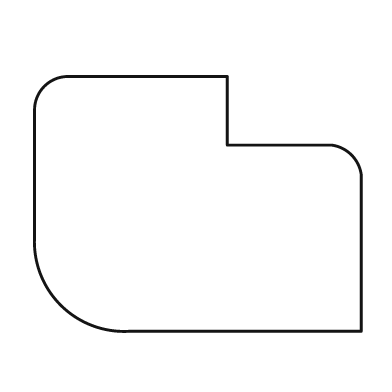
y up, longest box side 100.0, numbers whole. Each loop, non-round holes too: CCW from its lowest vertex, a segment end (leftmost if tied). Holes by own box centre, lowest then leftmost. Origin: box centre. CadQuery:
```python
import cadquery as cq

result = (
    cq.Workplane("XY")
    .moveTo(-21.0, -39.0)
    .lineTo(50.0, -39.0)
    .lineTo(50.0, 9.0)
    .threePointArc((47.0, 15.0), (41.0, 18.0))
    .lineTo(9.0, 18.0)
    .lineTo(9.0, 39.0)
    .lineTo(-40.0, 39.0)
    .threePointArc((-47.0, 36.0), (-50.0, 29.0))
    .lineTo(-50.0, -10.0)
    .threePointArc((-42.0, -31.0), (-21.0, -39.0))
    .close()
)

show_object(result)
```